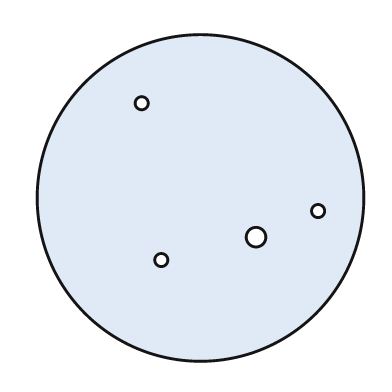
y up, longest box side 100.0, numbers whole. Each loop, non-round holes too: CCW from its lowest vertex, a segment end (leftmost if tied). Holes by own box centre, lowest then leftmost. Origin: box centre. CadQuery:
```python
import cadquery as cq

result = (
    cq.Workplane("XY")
    .moveTo(0.0, 0.0)
    .circle(50.0)
    .moveTo(-12.0, -19.0)
    .circle(2.0)
    .moveTo(17.0, -12.0)
    .circle(3.0)
    .moveTo(36.0, -4.0)
    .circle(2.0)
    .moveTo(-18.0, 29.0)
    .circle(2.0)
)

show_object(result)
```